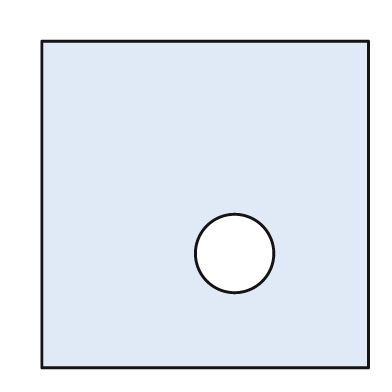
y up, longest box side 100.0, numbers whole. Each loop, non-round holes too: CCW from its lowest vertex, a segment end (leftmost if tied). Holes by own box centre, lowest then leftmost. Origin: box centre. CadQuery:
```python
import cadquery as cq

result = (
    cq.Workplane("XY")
    .moveTo(-50.0, -50.0)
    .lineTo(50.0, -50.0)
    .lineTo(50.0, 50.0)
    .lineTo(-50.0, 50.0)
    .close()
    .moveTo(9.0, -15.0)
    .circle(12.0)
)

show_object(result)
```